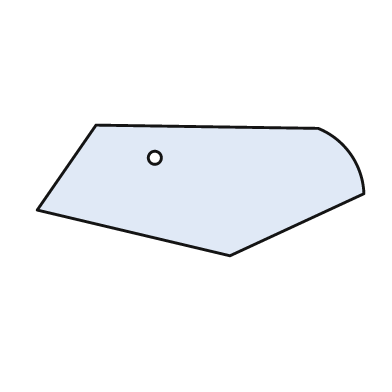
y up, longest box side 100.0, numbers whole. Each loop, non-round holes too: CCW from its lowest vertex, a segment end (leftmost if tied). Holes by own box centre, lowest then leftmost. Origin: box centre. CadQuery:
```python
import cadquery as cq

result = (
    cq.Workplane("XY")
    .moveTo(9.0, -20.0)
    .lineTo(50.0, -1.0)
    .threePointArc((46.0, 11.0), (36.0, 19.0))
    .lineTo(-32.0, 20.0)
    .lineTo(-50.0, -6.0)
    .close()
    .moveTo(-14.0, 10.0)
    .circle(2.0)
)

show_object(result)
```